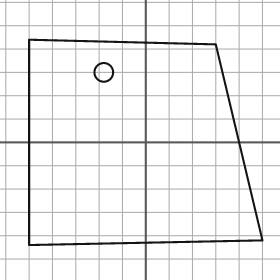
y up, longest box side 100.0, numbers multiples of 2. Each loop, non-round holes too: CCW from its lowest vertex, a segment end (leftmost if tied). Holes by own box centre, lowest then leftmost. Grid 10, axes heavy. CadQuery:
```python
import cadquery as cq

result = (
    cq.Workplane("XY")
    .moveTo(-50.0, -44.0)
    .lineTo(50.0, -42.0)
    .lineTo(30.0, 42.0)
    .lineTo(-50.0, 44.0)
    .close()
    .moveTo(-18.0, 30.0)
    .circle(4.0)
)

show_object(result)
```